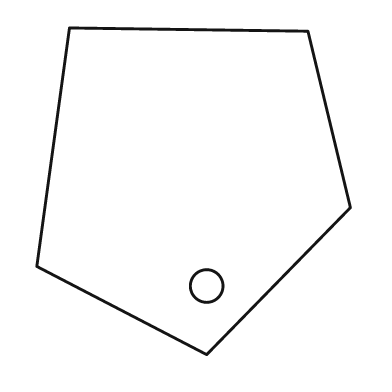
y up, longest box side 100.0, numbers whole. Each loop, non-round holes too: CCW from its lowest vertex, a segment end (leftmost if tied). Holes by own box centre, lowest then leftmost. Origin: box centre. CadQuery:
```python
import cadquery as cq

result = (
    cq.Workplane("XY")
    .moveTo(4.0, -50.0)
    .lineTo(48.0, -5.0)
    .lineTo(35.0, 49.0)
    .lineTo(-38.0, 50.0)
    .lineTo(-48.0, -23.0)
    .close()
    .moveTo(4.0, -29.0)
    .circle(5.0)
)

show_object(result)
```